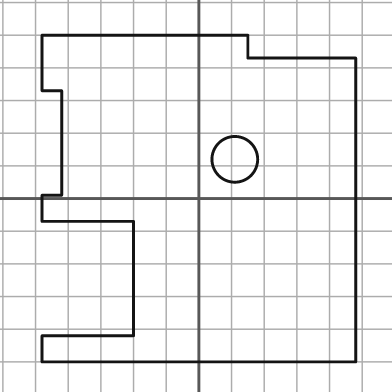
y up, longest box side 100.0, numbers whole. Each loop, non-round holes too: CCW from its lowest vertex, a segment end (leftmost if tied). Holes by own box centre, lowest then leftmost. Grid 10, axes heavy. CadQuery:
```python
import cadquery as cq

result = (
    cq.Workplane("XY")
    .moveTo(-48.0, -50.0)
    .lineTo(48.0, -50.0)
    .lineTo(48.0, 43.0)
    .lineTo(15.0, 43.0)
    .lineTo(15.0, 50.0)
    .lineTo(-48.0, 50.0)
    .lineTo(-48.0, 33.0)
    .lineTo(-42.0, 33.0)
    .lineTo(-42.0, 1.0)
    .lineTo(-48.0, 1.0)
    .lineTo(-48.0, -7.0)
    .lineTo(-20.0, -7.0)
    .lineTo(-20.0, -42.0)
    .lineTo(-48.0, -42.0)
    .close()
    .moveTo(11.0, 12.0)
    .circle(7.0)
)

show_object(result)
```